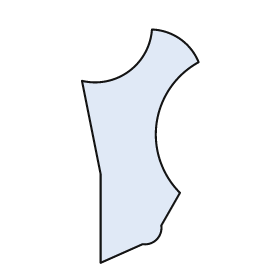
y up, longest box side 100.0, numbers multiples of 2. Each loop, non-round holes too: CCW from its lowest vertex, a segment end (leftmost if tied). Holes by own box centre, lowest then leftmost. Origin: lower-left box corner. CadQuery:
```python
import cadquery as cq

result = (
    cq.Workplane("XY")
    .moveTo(8.0, 0.0)
    .lineTo(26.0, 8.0)
    .threePointArc((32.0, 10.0), (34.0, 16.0))
    .lineTo(42.0, 30.0)
    .threePointArc((32.0, 60.0), (50.0, 86.0))
    .threePointArc((42.0, 96.0), (30.0, 100.0))
    .threePointArc((20.0, 82.0), (0.0, 78.0))
    .lineTo(8.0, 38.0)
    .close()
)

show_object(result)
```